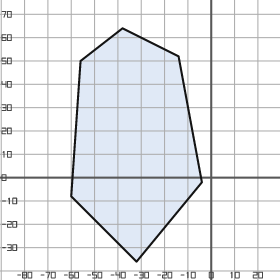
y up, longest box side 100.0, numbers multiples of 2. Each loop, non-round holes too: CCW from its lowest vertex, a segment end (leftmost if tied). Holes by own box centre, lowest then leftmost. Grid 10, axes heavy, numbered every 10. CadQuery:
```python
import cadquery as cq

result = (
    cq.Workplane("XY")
    .moveTo(-32.0, -36.0)
    .lineTo(-4.0, -2.0)
    .lineTo(-14.0, 52.0)
    .lineTo(-38.0, 64.0)
    .lineTo(-56.0, 50.0)
    .lineTo(-60.0, -8.0)
    .close()
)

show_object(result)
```